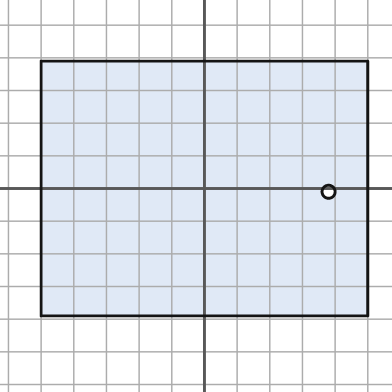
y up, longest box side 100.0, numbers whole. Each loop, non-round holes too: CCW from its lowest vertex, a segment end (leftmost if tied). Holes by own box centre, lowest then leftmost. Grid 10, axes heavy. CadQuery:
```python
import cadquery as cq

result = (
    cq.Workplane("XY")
    .moveTo(-50.0, -39.0)
    .lineTo(50.0, -39.0)
    .lineTo(50.0, 39.0)
    .lineTo(-50.0, 39.0)
    .close()
    .moveTo(38.0, -1.0)
    .circle(2.0)
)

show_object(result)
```